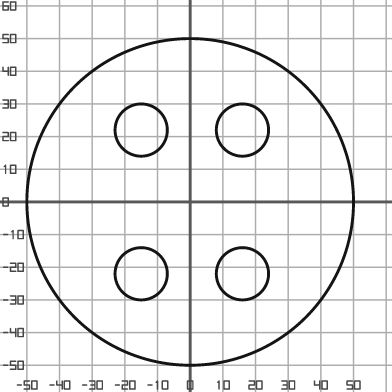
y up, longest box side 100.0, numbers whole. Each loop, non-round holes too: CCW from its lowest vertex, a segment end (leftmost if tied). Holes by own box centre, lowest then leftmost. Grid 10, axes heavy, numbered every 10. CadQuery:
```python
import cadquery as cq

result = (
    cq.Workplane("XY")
    .moveTo(0.0, 0.0)
    .circle(50.0)
    .moveTo(-15.0, -22.0)
    .circle(8.0)
    .moveTo(16.0, -22.0)
    .circle(8.0)
    .moveTo(-15.0, 22.0)
    .circle(8.0)
    .moveTo(16.0, 22.0)
    .circle(8.0)
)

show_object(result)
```